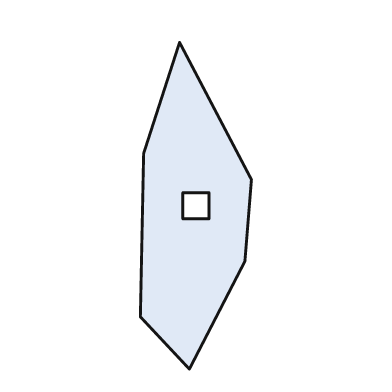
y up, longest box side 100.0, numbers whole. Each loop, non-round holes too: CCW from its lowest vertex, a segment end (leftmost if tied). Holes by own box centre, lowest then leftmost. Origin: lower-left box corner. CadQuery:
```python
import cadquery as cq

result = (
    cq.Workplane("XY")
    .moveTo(15.0, 0.0)
    .lineTo(32.0, 33.0)
    .lineTo(34.0, 58.0)
    .lineTo(12.0, 100.0)
    .lineTo(1.0, 66.0)
    .lineTo(0.0, 16.0)
    .close()
    .moveTo(13.0, 46.0)
    .lineTo(21.0, 46.0)
    .lineTo(21.0, 54.0)
    .lineTo(13.0, 54.0)
    .close()
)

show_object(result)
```